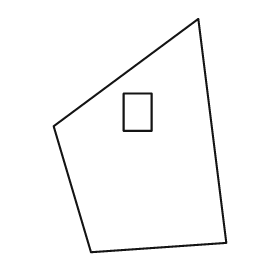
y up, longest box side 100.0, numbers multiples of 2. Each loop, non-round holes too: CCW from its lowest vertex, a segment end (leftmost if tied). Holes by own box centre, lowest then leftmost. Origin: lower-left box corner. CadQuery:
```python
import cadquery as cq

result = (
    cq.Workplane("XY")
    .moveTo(16.0, 0.0)
    .lineTo(74.0, 4.0)
    .lineTo(62.0, 100.0)
    .lineTo(0.0, 54.0)
    .close()
    .moveTo(30.0, 52.0)
    .lineTo(42.0, 52.0)
    .lineTo(42.0, 68.0)
    .lineTo(30.0, 68.0)
    .close()
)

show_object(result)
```